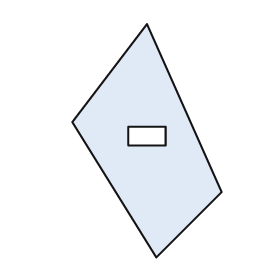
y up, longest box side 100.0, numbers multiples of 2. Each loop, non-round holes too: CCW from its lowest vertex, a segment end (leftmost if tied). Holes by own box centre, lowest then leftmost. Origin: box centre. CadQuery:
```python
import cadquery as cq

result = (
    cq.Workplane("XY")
    .moveTo(4.0, -50.0)
    .lineTo(32.0, -22.0)
    .lineTo(0.0, 50.0)
    .lineTo(-32.0, 8.0)
    .close()
    .moveTo(-8.0, -2.0)
    .lineTo(8.0, -2.0)
    .lineTo(8.0, 6.0)
    .lineTo(-8.0, 6.0)
    .close()
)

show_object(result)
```